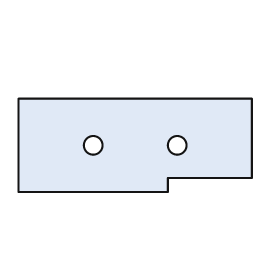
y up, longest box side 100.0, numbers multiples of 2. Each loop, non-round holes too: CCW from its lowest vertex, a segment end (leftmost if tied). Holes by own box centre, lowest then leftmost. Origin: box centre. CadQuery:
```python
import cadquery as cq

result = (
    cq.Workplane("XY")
    .moveTo(-50.0, -20.0)
    .lineTo(14.0, -20.0)
    .lineTo(14.0, -14.0)
    .lineTo(50.0, -14.0)
    .lineTo(50.0, 20.0)
    .lineTo(-50.0, 20.0)
    .close()
    .moveTo(-18.0, 0.0)
    .circle(4.0)
    .moveTo(18.0, 0.0)
    .circle(4.0)
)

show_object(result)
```